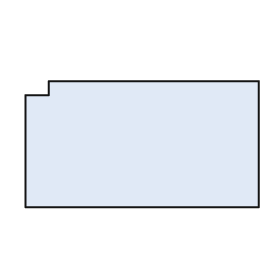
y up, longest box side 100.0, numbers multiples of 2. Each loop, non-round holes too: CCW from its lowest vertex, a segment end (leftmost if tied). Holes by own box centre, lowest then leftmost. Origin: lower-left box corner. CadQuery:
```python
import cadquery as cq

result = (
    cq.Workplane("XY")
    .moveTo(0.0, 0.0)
    .lineTo(100.0, 0.0)
    .lineTo(100.0, 54.0)
    .lineTo(10.0, 54.0)
    .lineTo(10.0, 48.0)
    .lineTo(0.0, 48.0)
    .close()
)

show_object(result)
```